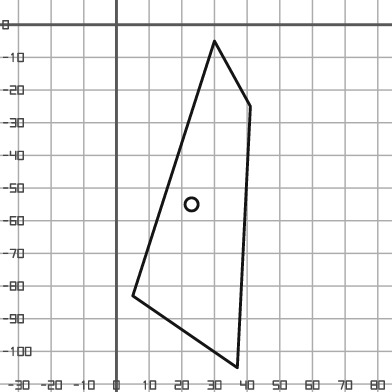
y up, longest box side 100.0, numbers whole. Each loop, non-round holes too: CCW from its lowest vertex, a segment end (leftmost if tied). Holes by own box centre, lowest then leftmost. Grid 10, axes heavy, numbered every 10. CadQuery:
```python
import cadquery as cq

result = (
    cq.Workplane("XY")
    .moveTo(37.0, -105.0)
    .lineTo(41.0, -25.0)
    .lineTo(30.0, -5.0)
    .lineTo(5.0, -83.0)
    .close()
    .moveTo(23.0, -55.0)
    .circle(2.0)
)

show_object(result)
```